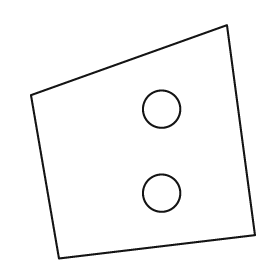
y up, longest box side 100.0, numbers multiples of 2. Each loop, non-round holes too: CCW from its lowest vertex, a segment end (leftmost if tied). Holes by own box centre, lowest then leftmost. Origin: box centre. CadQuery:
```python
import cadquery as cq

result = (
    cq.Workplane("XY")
    .moveTo(-36.0, -50.0)
    .lineTo(48.0, -40.0)
    .lineTo(36.0, 50.0)
    .lineTo(-48.0, 20.0)
    .close()
    .moveTo(8.0, -22.0)
    .circle(8.0)
    .moveTo(8.0, 14.0)
    .circle(8.0)
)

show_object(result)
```